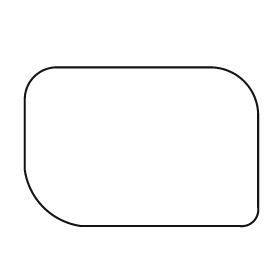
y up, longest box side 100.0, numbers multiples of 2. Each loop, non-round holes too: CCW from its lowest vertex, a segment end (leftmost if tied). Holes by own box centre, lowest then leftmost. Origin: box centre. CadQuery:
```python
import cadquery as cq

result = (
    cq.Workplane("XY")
    .moveTo(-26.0, -34.0)
    .lineTo(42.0, -34.0)
    .threePointArc((48.0, -32.0), (50.0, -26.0))
    .lineTo(50.0, 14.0)
    .threePointArc((44.0, 28.0), (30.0, 34.0))
    .lineTo(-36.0, 34.0)
    .threePointArc((-46.0, 30.0), (-50.0, 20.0))
    .lineTo(-50.0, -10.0)
    .threePointArc((-42.0, -26.0), (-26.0, -34.0))
    .close()
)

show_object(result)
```